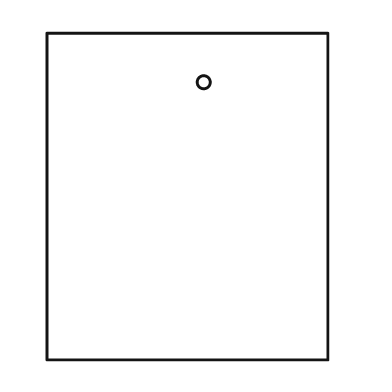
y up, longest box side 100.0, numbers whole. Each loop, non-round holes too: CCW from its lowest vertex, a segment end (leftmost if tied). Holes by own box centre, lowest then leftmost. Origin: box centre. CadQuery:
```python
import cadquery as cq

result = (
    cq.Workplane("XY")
    .moveTo(-43.0, -50.0)
    .lineTo(43.0, -50.0)
    .lineTo(43.0, 50.0)
    .lineTo(-43.0, 50.0)
    .close()
    .moveTo(5.0, 35.0)
    .circle(2.0)
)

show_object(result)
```